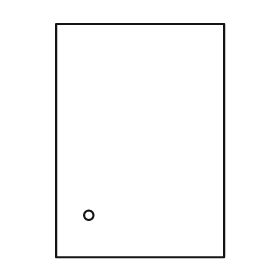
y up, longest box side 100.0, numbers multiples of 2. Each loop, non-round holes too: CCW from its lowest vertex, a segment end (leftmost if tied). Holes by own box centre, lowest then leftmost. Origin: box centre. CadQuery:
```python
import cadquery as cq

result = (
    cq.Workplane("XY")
    .moveTo(-36.0, -50.0)
    .lineTo(36.0, -50.0)
    .lineTo(36.0, 50.0)
    .lineTo(-36.0, 50.0)
    .close()
    .moveTo(-22.0, -32.0)
    .circle(2.0)
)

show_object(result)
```